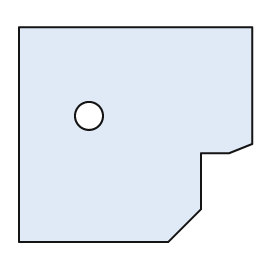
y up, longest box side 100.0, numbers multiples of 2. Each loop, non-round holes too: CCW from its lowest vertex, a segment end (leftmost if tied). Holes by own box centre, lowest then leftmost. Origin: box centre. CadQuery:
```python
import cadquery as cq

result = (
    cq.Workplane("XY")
    .moveTo(-50.0, -46.0)
    .lineTo(14.0, -46.0)
    .lineTo(28.0, -32.0)
    .lineTo(28.0, -8.0)
    .lineTo(40.0, -8.0)
    .lineTo(50.0, -4.0)
    .lineTo(50.0, 46.0)
    .lineTo(-50.0, 46.0)
    .close()
    .moveTo(-20.0, 8.0)
    .circle(6.0)
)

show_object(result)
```